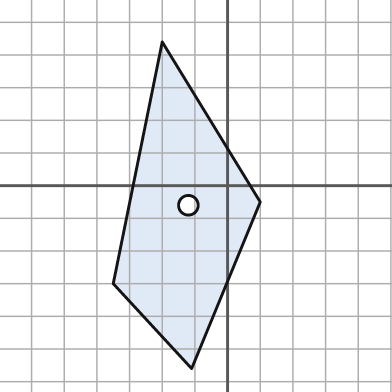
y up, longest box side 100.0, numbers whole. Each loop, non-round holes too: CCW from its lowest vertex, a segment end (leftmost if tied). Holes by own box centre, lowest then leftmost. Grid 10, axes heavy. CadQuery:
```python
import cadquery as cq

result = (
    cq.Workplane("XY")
    .moveTo(-11.0, -56.0)
    .lineTo(10.0, -5.0)
    .lineTo(-20.0, 44.0)
    .lineTo(-35.0, -30.0)
    .close()
    .moveTo(-12.0, -6.0)
    .circle(3.0)
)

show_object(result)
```